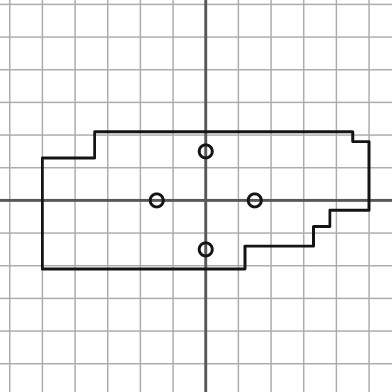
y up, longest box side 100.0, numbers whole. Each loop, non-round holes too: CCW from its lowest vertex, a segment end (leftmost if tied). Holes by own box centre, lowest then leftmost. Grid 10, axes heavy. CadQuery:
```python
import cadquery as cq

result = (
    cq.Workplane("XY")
    .moveTo(-50.0, -21.0)
    .lineTo(12.0, -21.0)
    .lineTo(12.0, -14.0)
    .lineTo(33.0, -14.0)
    .lineTo(33.0, -8.0)
    .lineTo(38.0, -8.0)
    .lineTo(38.0, -3.0)
    .lineTo(50.0, -3.0)
    .lineTo(50.0, 18.0)
    .lineTo(45.0, 18.0)
    .lineTo(45.0, 21.0)
    .lineTo(-34.0, 21.0)
    .lineTo(-34.0, 13.0)
    .lineTo(-50.0, 13.0)
    .close()
    .moveTo(0.0, -15.0)
    .circle(2.0)
    .moveTo(-15.0, 0.0)
    .circle(2.0)
    .moveTo(15.0, 0.0)
    .circle(2.0)
    .moveTo(0.0, 15.0)
    .circle(2.0)
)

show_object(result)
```